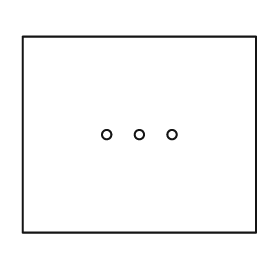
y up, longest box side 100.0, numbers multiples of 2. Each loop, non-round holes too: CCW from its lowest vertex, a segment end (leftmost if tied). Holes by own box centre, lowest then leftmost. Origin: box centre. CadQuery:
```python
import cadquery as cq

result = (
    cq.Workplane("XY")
    .moveTo(-50.0, -42.0)
    .lineTo(50.0, -42.0)
    .lineTo(50.0, 42.0)
    .lineTo(-50.0, 42.0)
    .close()
    .moveTo(-14.0, 0.0)
    .circle(2.0)
    .moveTo(0.0, 0.0)
    .circle(2.0)
    .moveTo(14.0, 0.0)
    .circle(2.0)
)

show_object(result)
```